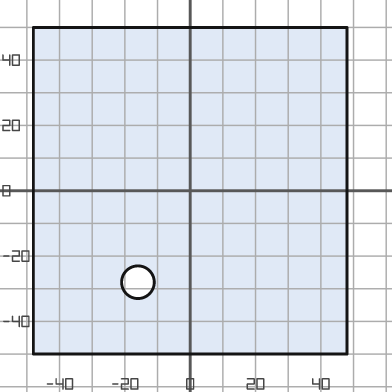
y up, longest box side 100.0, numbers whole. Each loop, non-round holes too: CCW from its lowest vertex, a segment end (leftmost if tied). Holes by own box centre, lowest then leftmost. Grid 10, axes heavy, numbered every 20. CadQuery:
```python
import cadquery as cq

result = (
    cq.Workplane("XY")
    .moveTo(-48.0, -50.0)
    .lineTo(48.0, -50.0)
    .lineTo(48.0, 50.0)
    .lineTo(-48.0, 50.0)
    .close()
    .moveTo(-16.0, -28.0)
    .circle(5.0)
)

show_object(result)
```